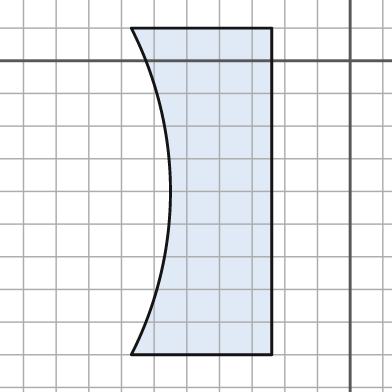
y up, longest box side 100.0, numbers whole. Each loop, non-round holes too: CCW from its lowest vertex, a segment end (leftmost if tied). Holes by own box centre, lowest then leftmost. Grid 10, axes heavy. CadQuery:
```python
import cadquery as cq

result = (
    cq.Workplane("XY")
    .moveTo(-67.0, -90.0)
    .lineTo(-24.0, -90.0)
    .lineTo(-24.0, 10.0)
    .lineTo(-67.0, 10.0)
    .threePointArc((-55.0, -40.0), (-67.0, -90.0))
    .close()
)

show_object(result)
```